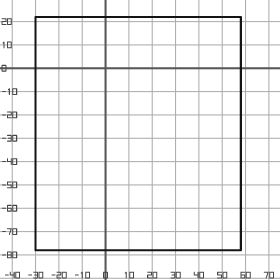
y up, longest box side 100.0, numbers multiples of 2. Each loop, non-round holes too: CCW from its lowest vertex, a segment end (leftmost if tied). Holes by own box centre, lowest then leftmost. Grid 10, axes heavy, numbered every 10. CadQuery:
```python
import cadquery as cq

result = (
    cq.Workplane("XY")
    .moveTo(-30.0, -78.0)
    .lineTo(58.0, -78.0)
    .lineTo(58.0, 22.0)
    .lineTo(-30.0, 22.0)
    .close()
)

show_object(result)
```